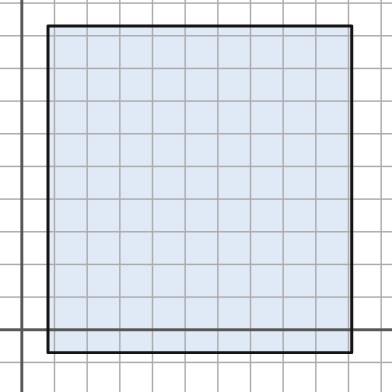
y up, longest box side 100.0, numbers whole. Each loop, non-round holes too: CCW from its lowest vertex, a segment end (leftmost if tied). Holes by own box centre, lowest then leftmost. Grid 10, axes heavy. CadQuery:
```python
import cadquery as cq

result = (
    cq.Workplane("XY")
    .moveTo(8.0, -7.0)
    .lineTo(101.0, -7.0)
    .lineTo(101.0, 93.0)
    .lineTo(8.0, 93.0)
    .close()
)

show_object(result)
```